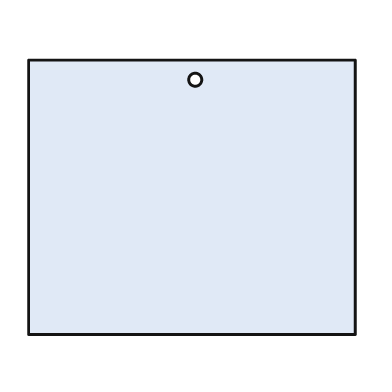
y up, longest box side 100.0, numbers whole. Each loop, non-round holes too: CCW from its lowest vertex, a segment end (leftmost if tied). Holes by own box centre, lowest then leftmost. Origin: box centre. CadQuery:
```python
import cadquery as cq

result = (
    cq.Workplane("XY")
    .moveTo(-50.0, -42.0)
    .lineTo(50.0, -42.0)
    .lineTo(50.0, 42.0)
    .lineTo(-50.0, 42.0)
    .close()
    .moveTo(1.0, 36.0)
    .circle(2.0)
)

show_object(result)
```